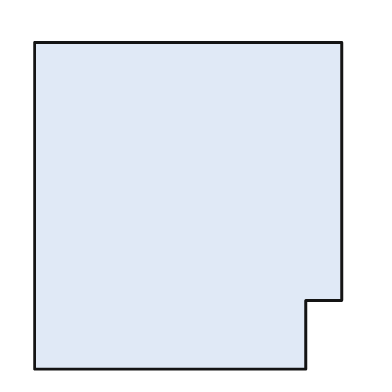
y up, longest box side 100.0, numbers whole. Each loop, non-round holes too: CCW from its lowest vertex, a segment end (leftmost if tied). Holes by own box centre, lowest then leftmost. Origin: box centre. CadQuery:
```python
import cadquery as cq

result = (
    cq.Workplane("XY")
    .moveTo(-47.0, -50.0)
    .lineTo(36.0, -50.0)
    .lineTo(36.0, -29.0)
    .lineTo(47.0, -29.0)
    .lineTo(47.0, 50.0)
    .lineTo(-47.0, 50.0)
    .close()
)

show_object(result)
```